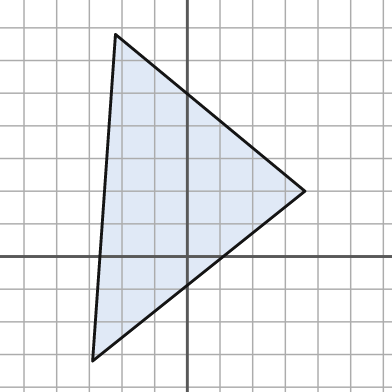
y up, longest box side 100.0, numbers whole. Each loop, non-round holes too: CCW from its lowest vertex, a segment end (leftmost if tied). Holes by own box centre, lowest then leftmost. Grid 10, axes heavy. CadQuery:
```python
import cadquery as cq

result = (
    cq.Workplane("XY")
    .moveTo(-29.0, -32.0)
    .lineTo(36.0, 20.0)
    .lineTo(-22.0, 68.0)
    .close()
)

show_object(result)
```